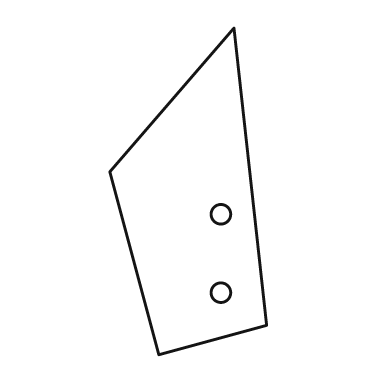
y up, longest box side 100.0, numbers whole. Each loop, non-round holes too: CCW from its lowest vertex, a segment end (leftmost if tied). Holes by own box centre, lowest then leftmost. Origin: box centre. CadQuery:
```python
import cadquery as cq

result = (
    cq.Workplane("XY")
    .moveTo(-9.0, -50.0)
    .lineTo(24.0, -41.0)
    .lineTo(14.0, 50.0)
    .lineTo(-24.0, 6.0)
    .close()
    .moveTo(10.0, -31.0)
    .circle(3.0)
    .moveTo(10.0, -7.0)
    .circle(3.0)
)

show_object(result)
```